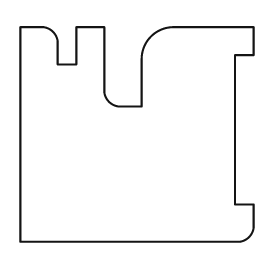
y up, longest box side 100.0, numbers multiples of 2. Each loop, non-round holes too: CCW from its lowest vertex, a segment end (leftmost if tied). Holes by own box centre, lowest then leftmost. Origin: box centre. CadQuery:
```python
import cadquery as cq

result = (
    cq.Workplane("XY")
    .moveTo(-50.0, -46.0)
    .lineTo(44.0, -46.0)
    .threePointArc((48.0, -44.0), (50.0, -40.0))
    .lineTo(50.0, -30.0)
    .lineTo(42.0, -30.0)
    .lineTo(42.0, 34.0)
    .lineTo(50.0, 34.0)
    .lineTo(50.0, 46.0)
    .lineTo(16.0, 46.0)
    .threePointArc((6.0, 42.0), (2.0, 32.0))
    .lineTo(2.0, 12.0)
    .lineTo(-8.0, 12.0)
    .threePointArc((-12.0, 14.0), (-14.0, 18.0))
    .lineTo(-14.0, 46.0)
    .lineTo(-26.0, 46.0)
    .lineTo(-26.0, 30.0)
    .lineTo(-34.0, 30.0)
    .lineTo(-34.0, 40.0)
    .threePointArc((-36.0, 44.0), (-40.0, 46.0))
    .lineTo(-50.0, 46.0)
    .close()
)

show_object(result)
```